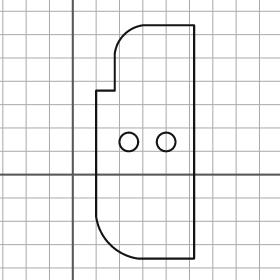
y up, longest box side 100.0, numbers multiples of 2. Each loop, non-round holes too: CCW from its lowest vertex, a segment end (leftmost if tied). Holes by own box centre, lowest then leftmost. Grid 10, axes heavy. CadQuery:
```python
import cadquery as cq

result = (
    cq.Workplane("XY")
    .moveTo(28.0, -36.0)
    .lineTo(52.0, -36.0)
    .lineTo(52.0, 64.0)
    .lineTo(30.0, 64.0)
    .threePointArc((22.0, 60.0), (18.0, 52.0))
    .lineTo(18.0, 36.0)
    .lineTo(10.0, 36.0)
    .lineTo(10.0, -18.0)
    .threePointArc((16.0, -30.0), (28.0, -36.0))
    .close()
    .moveTo(24.0, 14.0)
    .circle(4.0)
    .moveTo(40.0, 14.0)
    .circle(4.0)
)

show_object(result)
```